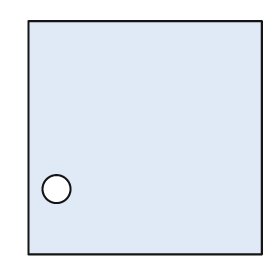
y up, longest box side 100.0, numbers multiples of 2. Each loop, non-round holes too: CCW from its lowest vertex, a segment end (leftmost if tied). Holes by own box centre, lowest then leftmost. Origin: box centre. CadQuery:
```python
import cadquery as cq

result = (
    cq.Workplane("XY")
    .moveTo(-50.0, -50.0)
    .lineTo(50.0, -50.0)
    .lineTo(50.0, 50.0)
    .lineTo(-50.0, 50.0)
    .close()
    .moveTo(-38.0, -22.0)
    .circle(6.0)
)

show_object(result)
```